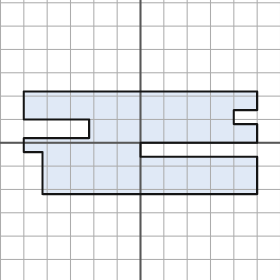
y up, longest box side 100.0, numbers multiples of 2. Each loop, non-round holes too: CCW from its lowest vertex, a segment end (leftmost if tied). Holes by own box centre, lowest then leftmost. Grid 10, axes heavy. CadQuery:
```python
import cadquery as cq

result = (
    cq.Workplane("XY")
    .moveTo(-42.0, -22.0)
    .lineTo(50.0, -22.0)
    .lineTo(50.0, -6.0)
    .lineTo(0.0, -6.0)
    .lineTo(0.0, 0.0)
    .lineTo(50.0, 0.0)
    .lineTo(50.0, 8.0)
    .lineTo(40.0, 8.0)
    .lineTo(40.0, 14.0)
    .lineTo(50.0, 14.0)
    .lineTo(50.0, 22.0)
    .lineTo(-50.0, 22.0)
    .lineTo(-50.0, 10.0)
    .lineTo(-22.0, 10.0)
    .lineTo(-22.0, 2.0)
    .lineTo(-50.0, 2.0)
    .lineTo(-50.0, -4.0)
    .lineTo(-42.0, -4.0)
    .close()
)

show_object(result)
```